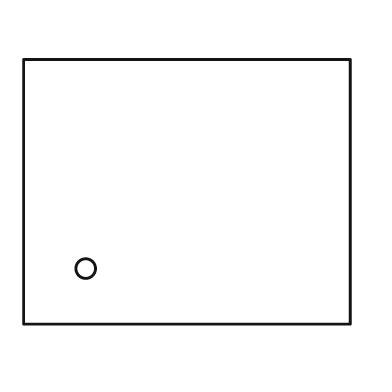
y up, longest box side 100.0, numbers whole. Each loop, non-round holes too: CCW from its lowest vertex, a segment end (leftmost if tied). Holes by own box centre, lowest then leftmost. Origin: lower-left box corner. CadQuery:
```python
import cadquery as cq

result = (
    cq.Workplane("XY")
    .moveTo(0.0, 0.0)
    .lineTo(100.0, 0.0)
    .lineTo(100.0, 81.0)
    .lineTo(0.0, 81.0)
    .close()
    .moveTo(19.0, 17.0)
    .circle(3.0)
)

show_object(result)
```